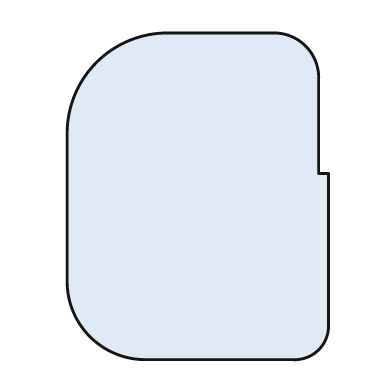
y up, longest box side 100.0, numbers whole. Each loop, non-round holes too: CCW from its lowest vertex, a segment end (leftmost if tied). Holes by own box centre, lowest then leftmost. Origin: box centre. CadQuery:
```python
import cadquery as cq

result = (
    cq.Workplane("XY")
    .moveTo(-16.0, -50.0)
    .lineTo(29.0, -50.0)
    .threePointArc((37.0, -47.0), (40.0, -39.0))
    .lineTo(40.0, 7.0)
    .lineTo(37.0, 7.0)
    .lineTo(37.0, 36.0)
    .threePointArc((33.0, 46.0), (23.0, 50.0))
    .lineTo(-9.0, 50.0)
    .threePointArc((-31.0, 41.0), (-40.0, 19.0))
    .lineTo(-40.0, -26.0)
    .threePointArc((-33.0, -43.0), (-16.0, -50.0))
    .close()
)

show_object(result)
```